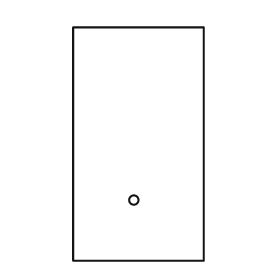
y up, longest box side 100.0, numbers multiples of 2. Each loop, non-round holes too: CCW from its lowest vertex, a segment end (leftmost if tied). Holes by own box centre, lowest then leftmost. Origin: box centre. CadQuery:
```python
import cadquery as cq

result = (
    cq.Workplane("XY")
    .moveTo(-28.0, -50.0)
    .lineTo(28.0, -50.0)
    .lineTo(28.0, 50.0)
    .lineTo(-28.0, 50.0)
    .close()
    .moveTo(-2.0, -24.0)
    .circle(2.0)
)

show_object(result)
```